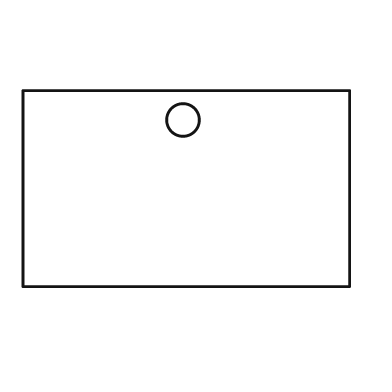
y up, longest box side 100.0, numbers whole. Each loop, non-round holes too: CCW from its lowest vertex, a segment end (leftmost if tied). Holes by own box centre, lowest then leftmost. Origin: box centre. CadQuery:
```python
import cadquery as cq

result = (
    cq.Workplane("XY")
    .moveTo(-50.0, -30.0)
    .lineTo(50.0, -30.0)
    .lineTo(50.0, 30.0)
    .lineTo(-50.0, 30.0)
    .close()
    .moveTo(-1.0, 21.0)
    .circle(5.0)
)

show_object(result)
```